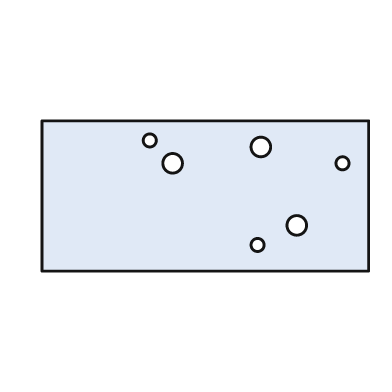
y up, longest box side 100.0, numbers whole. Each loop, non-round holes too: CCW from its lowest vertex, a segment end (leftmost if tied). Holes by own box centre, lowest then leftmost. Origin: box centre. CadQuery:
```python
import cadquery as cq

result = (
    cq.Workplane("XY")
    .moveTo(-50.0, -23.0)
    .lineTo(50.0, -23.0)
    .lineTo(50.0, 23.0)
    .lineTo(-50.0, 23.0)
    .close()
    .moveTo(16.0, -15.0)
    .circle(2.0)
    .moveTo(28.0, -9.0)
    .circle(3.0)
    .moveTo(-10.0, 10.0)
    .circle(3.0)
    .moveTo(42.0, 10.0)
    .circle(2.0)
    .moveTo(17.0, 15.0)
    .circle(3.0)
    .moveTo(-17.0, 17.0)
    .circle(2.0)
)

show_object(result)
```